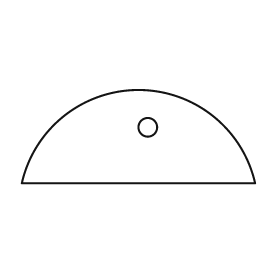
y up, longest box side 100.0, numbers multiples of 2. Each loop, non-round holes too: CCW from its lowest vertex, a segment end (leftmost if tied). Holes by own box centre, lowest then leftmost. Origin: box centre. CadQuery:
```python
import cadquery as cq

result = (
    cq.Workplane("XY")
    .moveTo(-50.0, -20.0)
    .lineTo(50.0, -20.0)
    .threePointArc((0.0, 20.0), (-50.0, -20.0))
    .close()
    .moveTo(4.0, 4.0)
    .circle(4.0)
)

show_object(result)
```